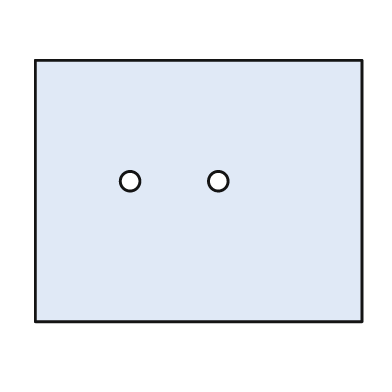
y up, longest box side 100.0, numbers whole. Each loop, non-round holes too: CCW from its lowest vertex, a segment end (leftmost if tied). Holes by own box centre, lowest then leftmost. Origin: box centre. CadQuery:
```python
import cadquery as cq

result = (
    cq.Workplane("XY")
    .moveTo(-50.0, -40.0)
    .lineTo(50.0, -40.0)
    .lineTo(50.0, 40.0)
    .lineTo(-50.0, 40.0)
    .close()
    .moveTo(-21.0, 3.0)
    .circle(3.0)
    .moveTo(6.0, 3.0)
    .circle(3.0)
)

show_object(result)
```